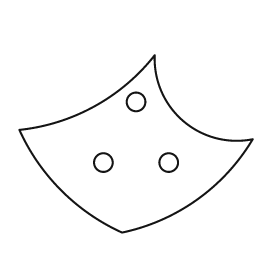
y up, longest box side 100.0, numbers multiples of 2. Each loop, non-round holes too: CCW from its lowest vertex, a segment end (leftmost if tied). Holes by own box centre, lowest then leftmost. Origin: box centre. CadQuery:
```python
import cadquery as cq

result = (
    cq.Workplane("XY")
    .moveTo(-6.0, -38.0)
    .threePointArc((26.0, -24.0), (50.0, 2.0))
    .threePointArc((20.0, 10.0), (8.0, 38.0))
    .threePointArc((-18.0, 16.0), (-50.0, 6.0))
    .threePointArc((-32.0, -20.0), (-6.0, -38.0))
    .close()
    .moveTo(-14.0, -8.0)
    .circle(4.0)
    .moveTo(14.0, -8.0)
    .circle(4.0)
    .moveTo(0.0, 18.0)
    .circle(4.0)
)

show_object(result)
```